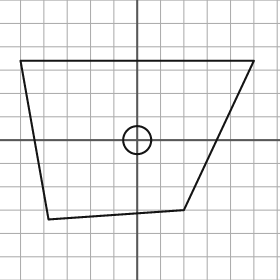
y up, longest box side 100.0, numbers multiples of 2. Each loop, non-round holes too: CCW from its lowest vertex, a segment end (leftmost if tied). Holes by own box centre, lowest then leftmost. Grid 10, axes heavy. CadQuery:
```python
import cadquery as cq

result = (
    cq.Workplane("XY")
    .moveTo(-38.0, -34.0)
    .lineTo(20.0, -30.0)
    .lineTo(50.0, 34.0)
    .lineTo(-50.0, 34.0)
    .close()
    .moveTo(0.0, 0.0)
    .circle(6.0)
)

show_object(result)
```